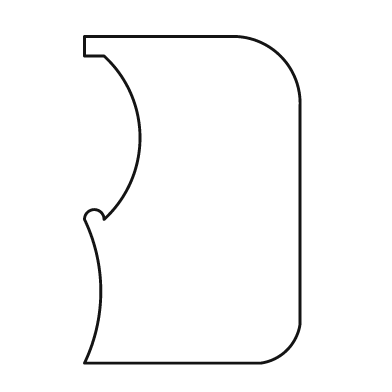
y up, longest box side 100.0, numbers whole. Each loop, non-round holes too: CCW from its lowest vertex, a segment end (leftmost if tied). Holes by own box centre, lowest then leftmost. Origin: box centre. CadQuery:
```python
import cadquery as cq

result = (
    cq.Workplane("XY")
    .moveTo(-33.0, -50.0)
    .lineTo(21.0, -50.0)
    .threePointArc((29.0, -46.0), (33.0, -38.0))
    .lineTo(33.0, 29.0)
    .threePointArc((27.0, 44.0), (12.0, 50.0))
    .lineTo(-33.0, 50.0)
    .lineTo(-33.0, 44.0)
    .lineTo(-27.0, 44.0)
    .threePointArc((-16.0, 19.0), (-27.0, -6.0))
    .threePointArc((-30.0, -3.0), (-33.0, -6.0))
    .threePointArc((-28.0, -28.0), (-33.0, -50.0))
    .close()
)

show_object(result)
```